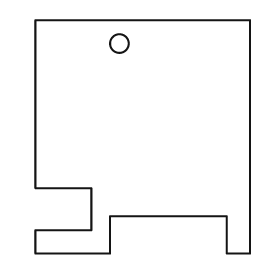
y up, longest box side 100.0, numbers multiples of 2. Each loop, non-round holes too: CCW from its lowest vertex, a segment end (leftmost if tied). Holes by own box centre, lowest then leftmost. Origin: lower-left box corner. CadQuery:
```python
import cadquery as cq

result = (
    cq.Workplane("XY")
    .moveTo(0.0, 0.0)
    .lineTo(32.0, 0.0)
    .lineTo(32.0, 16.0)
    .lineTo(82.0, 16.0)
    .lineTo(82.0, 0.0)
    .lineTo(92.0, 0.0)
    .lineTo(92.0, 100.0)
    .lineTo(0.0, 100.0)
    .lineTo(0.0, 28.0)
    .lineTo(24.0, 28.0)
    .lineTo(24.0, 10.0)
    .lineTo(0.0, 10.0)
    .close()
    .moveTo(36.0, 90.0)
    .circle(4.0)
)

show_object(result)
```